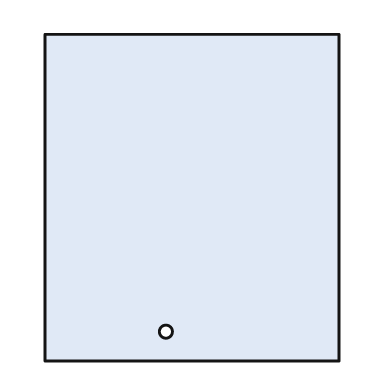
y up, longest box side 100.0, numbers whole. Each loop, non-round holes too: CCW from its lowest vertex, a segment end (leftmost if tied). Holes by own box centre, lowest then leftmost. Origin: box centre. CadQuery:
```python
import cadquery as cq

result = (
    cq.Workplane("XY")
    .moveTo(-45.0, -50.0)
    .lineTo(45.0, -50.0)
    .lineTo(45.0, 50.0)
    .lineTo(-45.0, 50.0)
    .close()
    .moveTo(-8.0, -41.0)
    .circle(2.0)
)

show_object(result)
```